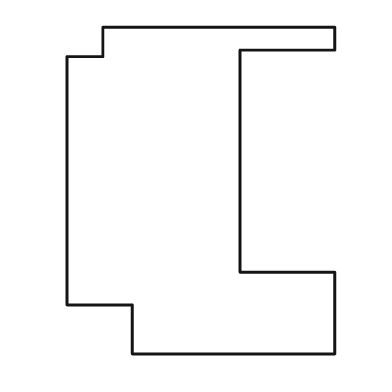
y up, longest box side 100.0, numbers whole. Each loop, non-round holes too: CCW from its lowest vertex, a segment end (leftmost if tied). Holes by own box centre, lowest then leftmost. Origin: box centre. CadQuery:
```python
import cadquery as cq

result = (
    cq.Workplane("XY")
    .moveTo(-21.0, -50.0)
    .lineTo(41.0, -50.0)
    .lineTo(41.0, -25.0)
    .lineTo(12.0, -25.0)
    .lineTo(12.0, 43.0)
    .lineTo(41.0, 43.0)
    .lineTo(41.0, 50.0)
    .lineTo(-30.0, 50.0)
    .lineTo(-30.0, 41.0)
    .lineTo(-41.0, 41.0)
    .lineTo(-41.0, -35.0)
    .lineTo(-21.0, -35.0)
    .close()
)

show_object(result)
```